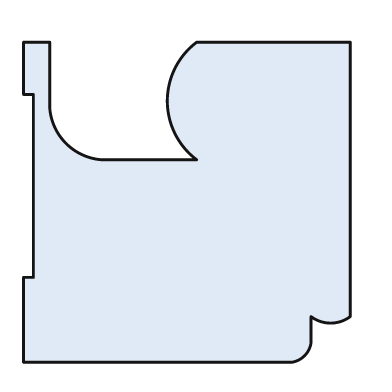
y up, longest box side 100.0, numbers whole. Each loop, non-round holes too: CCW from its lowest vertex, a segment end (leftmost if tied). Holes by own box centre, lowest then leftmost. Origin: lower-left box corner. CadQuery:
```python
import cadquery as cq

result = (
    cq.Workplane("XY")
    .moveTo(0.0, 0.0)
    .lineTo(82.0, 0.0)
    .threePointArc((86.0, 2.0), (88.0, 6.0))
    .lineTo(88.0, 14.0)
    .threePointArc((94.0, 12.0), (100.0, 14.0))
    .lineTo(100.0, 98.0)
    .lineTo(53.0, 98.0)
    .threePointArc((44.0, 80.0), (53.0, 62.0))
    .lineTo(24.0, 62.0)
    .threePointArc((13.0, 67.0), (8.0, 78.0))
    .lineTo(8.0, 98.0)
    .lineTo(0.0, 98.0)
    .lineTo(0.0, 82.0)
    .lineTo(3.0, 82.0)
    .lineTo(3.0, 26.0)
    .lineTo(0.0, 26.0)
    .close()
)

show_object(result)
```